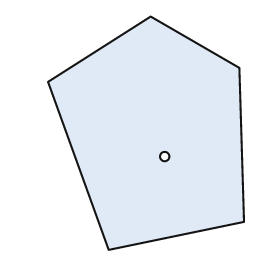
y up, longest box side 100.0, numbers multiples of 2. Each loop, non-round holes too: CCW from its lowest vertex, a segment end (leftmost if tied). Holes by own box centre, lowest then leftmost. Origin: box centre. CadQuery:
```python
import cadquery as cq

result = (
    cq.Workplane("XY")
    .moveTo(-16.0, -50.0)
    .lineTo(42.0, -38.0)
    .lineTo(40.0, 28.0)
    .lineTo(2.0, 50.0)
    .lineTo(-42.0, 22.0)
    .close()
    .moveTo(8.0, -10.0)
    .circle(2.0)
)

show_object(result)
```